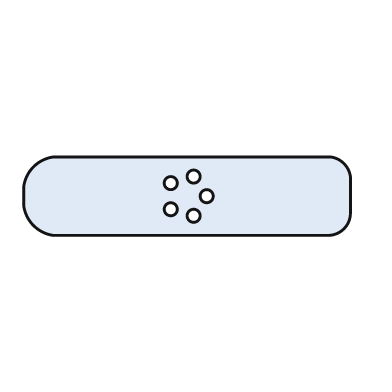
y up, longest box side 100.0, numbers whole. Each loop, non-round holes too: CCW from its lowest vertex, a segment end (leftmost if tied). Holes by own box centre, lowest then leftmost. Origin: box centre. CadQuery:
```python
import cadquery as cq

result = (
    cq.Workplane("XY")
    .moveTo(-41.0, -12.0)
    .lineTo(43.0, -12.0)
    .threePointArc((48.0, -10.0), (50.0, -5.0))
    .lineTo(50.0, 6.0)
    .threePointArc((48.0, 10.0), (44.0, 12.0))
    .lineTo(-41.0, 12.0)
    .threePointArc((-47.0, 9.0), (-50.0, 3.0))
    .lineTo(-50.0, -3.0)
    .threePointArc((-47.0, -9.0), (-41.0, -12.0))
    .close()
    .moveTo(2.0, -6.0)
    .circle(2.0)
    .moveTo(-5.0, -4.0)
    .circle(2.0)
    .moveTo(6.0, 0.0)
    .circle(2.0)
    .moveTo(-5.0, 4.0)
    .circle(2.0)
    .moveTo(2.0, 6.0)
    .circle(2.0)
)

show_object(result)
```